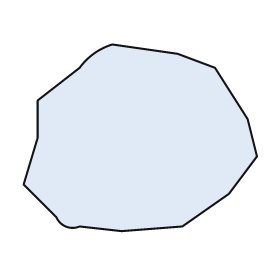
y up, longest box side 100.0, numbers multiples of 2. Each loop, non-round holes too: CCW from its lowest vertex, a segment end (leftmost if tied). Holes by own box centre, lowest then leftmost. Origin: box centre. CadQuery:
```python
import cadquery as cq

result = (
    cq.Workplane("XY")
    .moveTo(-8.0, -40.0)
    .lineTo(18.0, -38.0)
    .lineTo(38.0, -24.0)
    .lineTo(50.0, -8.0)
    .lineTo(46.0, 8.0)
    .lineTo(32.0, 30.0)
    .lineTo(16.0, 36.0)
    .lineTo(-12.0, 40.0)
    .threePointArc((-20.0, 36.0), (-26.0, 30.0))
    .lineTo(-44.0, 16.0)
    .lineTo(-44.0, 0.0)
    .lineTo(-50.0, -20.0)
    .lineTo(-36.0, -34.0)
    .threePointArc((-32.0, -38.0), (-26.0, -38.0))
    .close()
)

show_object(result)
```